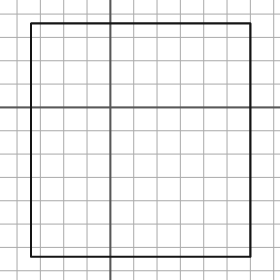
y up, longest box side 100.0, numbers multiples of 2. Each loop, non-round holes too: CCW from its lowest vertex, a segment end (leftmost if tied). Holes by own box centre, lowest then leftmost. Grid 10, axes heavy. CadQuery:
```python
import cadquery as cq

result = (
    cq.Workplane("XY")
    .moveTo(-34.0, -64.0)
    .lineTo(60.0, -64.0)
    .lineTo(60.0, 36.0)
    .lineTo(-34.0, 36.0)
    .close()
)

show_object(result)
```